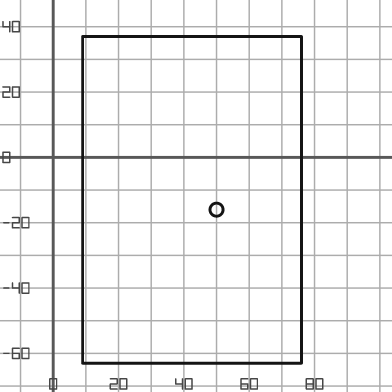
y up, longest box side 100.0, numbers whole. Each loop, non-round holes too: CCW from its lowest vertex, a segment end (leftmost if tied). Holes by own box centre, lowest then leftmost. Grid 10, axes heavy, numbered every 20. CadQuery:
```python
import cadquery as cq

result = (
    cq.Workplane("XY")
    .moveTo(9.0, -63.0)
    .lineTo(76.0, -63.0)
    .lineTo(76.0, 37.0)
    .lineTo(9.0, 37.0)
    .close()
    .moveTo(50.0, -16.0)
    .circle(2.0)
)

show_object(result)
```